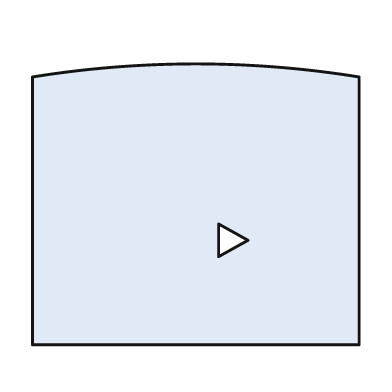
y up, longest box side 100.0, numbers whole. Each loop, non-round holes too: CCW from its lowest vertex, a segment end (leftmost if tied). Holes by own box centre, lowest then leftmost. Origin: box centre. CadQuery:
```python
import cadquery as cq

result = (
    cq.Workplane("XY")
    .moveTo(-50.0, -43.0)
    .lineTo(50.0, -43.0)
    .lineTo(50.0, 39.0)
    .threePointArc((0.0, 43.0), (-50.0, 39.0))
    .close()
    .moveTo(7.0, -16.0)
    .lineTo(16.0, -11.0)
    .lineTo(7.0, -6.0)
    .close()
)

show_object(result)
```